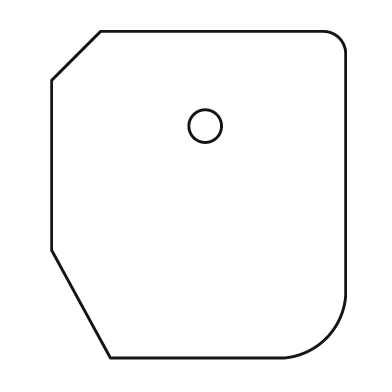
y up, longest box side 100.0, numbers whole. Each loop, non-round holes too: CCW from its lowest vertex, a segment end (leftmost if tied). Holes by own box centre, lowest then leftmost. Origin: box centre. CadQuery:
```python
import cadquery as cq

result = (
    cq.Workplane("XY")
    .moveTo(-27.0, -50.0)
    .lineTo(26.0, -50.0)
    .threePointArc((39.0, -44.0), (45.0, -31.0))
    .lineTo(45.0, 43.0)
    .threePointArc((43.0, 48.0), (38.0, 50.0))
    .lineTo(-30.0, 50.0)
    .lineTo(-45.0, 35.0)
    .lineTo(-45.0, -17.0)
    .close()
    .moveTo(2.0, 21.0)
    .circle(5.0)
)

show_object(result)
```